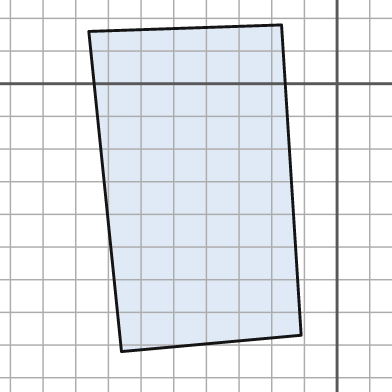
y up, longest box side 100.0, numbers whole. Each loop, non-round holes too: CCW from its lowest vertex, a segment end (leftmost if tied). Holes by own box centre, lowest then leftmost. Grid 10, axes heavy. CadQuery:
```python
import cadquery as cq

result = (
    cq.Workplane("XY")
    .moveTo(-66.0, -82.0)
    .lineTo(-11.0, -77.0)
    .lineTo(-17.0, 18.0)
    .lineTo(-76.0, 16.0)
    .close()
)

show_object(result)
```